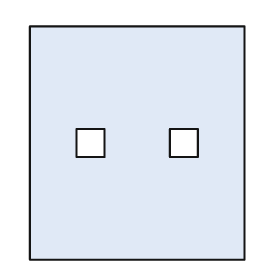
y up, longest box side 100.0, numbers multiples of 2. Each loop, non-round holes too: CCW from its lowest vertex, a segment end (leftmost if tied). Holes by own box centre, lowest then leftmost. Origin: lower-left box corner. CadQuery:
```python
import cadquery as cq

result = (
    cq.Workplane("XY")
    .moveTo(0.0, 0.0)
    .lineTo(92.0, 0.0)
    .lineTo(92.0, 100.0)
    .lineTo(0.0, 100.0)
    .close()
    .moveTo(20.0, 44.0)
    .lineTo(32.0, 44.0)
    .lineTo(32.0, 56.0)
    .lineTo(20.0, 56.0)
    .close()
    .moveTo(60.0, 44.0)
    .lineTo(72.0, 44.0)
    .lineTo(72.0, 56.0)
    .lineTo(60.0, 56.0)
    .close()
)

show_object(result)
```